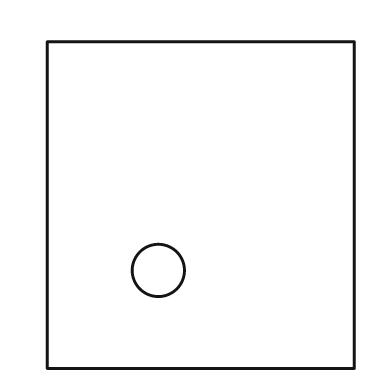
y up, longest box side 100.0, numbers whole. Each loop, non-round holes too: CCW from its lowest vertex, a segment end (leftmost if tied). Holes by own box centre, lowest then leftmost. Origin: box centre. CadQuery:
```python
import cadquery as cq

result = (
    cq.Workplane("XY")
    .moveTo(-47.0, -50.0)
    .lineTo(47.0, -50.0)
    .lineTo(47.0, 50.0)
    .lineTo(-47.0, 50.0)
    .close()
    .moveTo(-13.0, -20.0)
    .circle(8.0)
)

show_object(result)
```